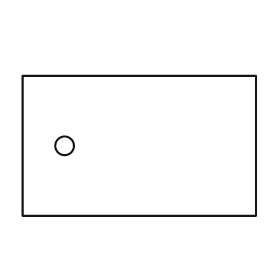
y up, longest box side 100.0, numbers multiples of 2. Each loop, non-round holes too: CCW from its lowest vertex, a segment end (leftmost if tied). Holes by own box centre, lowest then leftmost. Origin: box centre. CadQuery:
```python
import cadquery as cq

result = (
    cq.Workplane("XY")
    .moveTo(-50.0, -30.0)
    .lineTo(50.0, -30.0)
    .lineTo(50.0, 30.0)
    .lineTo(-50.0, 30.0)
    .close()
    .moveTo(-32.0, 0.0)
    .circle(4.0)
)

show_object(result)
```